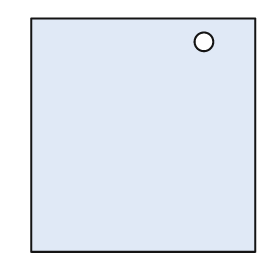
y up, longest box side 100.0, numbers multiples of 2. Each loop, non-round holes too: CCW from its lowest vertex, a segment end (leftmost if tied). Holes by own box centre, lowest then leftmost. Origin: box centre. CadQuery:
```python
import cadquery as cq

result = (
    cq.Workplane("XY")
    .moveTo(-48.0, -50.0)
    .lineTo(48.0, -50.0)
    .lineTo(48.0, 50.0)
    .lineTo(-48.0, 50.0)
    .close()
    .moveTo(26.0, 40.0)
    .circle(4.0)
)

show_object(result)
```